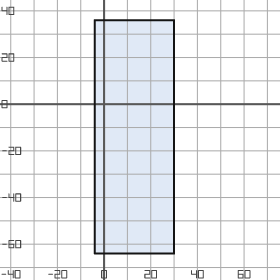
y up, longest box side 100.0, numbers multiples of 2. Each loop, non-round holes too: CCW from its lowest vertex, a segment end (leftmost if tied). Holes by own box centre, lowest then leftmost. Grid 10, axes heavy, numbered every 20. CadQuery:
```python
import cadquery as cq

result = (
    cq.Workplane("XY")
    .moveTo(-4.0, -64.0)
    .lineTo(30.0, -64.0)
    .lineTo(30.0, 36.0)
    .lineTo(-4.0, 36.0)
    .close()
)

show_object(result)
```